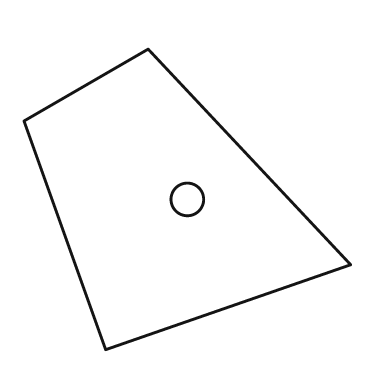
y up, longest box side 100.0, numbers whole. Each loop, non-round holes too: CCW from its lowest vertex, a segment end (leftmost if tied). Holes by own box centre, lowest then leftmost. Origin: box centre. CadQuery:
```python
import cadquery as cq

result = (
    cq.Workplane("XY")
    .moveTo(-25.0, -46.0)
    .lineTo(50.0, -20.0)
    .lineTo(-12.0, 46.0)
    .lineTo(-50.0, 24.0)
    .close()
    .moveTo(0.0, 0.0)
    .circle(5.0)
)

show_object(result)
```